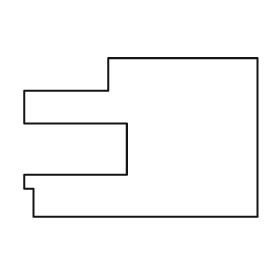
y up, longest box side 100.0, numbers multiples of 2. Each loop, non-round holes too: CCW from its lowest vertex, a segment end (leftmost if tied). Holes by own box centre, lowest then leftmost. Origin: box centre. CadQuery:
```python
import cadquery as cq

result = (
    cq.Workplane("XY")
    .moveTo(-46.0, -34.0)
    .lineTo(50.0, -34.0)
    .lineTo(50.0, 34.0)
    .lineTo(-14.0, 34.0)
    .lineTo(-14.0, 20.0)
    .lineTo(-50.0, 20.0)
    .lineTo(-50.0, 6.0)
    .lineTo(-6.0, 6.0)
    .lineTo(-6.0, -16.0)
    .lineTo(-50.0, -16.0)
    .lineTo(-50.0, -22.0)
    .lineTo(-46.0, -22.0)
    .close()
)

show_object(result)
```